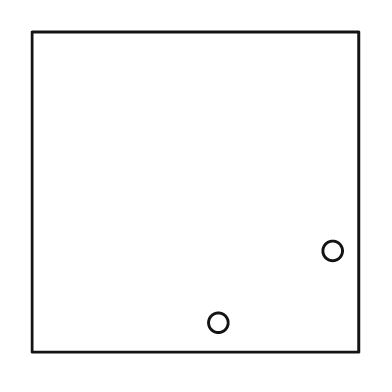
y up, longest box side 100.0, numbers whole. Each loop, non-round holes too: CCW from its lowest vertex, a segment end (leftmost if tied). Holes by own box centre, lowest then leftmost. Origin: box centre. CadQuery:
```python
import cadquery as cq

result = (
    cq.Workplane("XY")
    .moveTo(-50.0, -49.0)
    .lineTo(50.0, -49.0)
    .lineTo(50.0, 49.0)
    .lineTo(-50.0, 49.0)
    .close()
    .moveTo(7.0, -40.0)
    .circle(3.0)
    .moveTo(42.0, -18.0)
    .circle(3.0)
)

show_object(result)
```